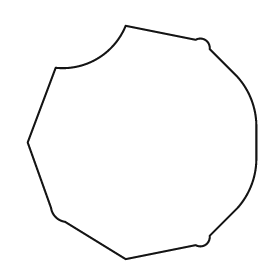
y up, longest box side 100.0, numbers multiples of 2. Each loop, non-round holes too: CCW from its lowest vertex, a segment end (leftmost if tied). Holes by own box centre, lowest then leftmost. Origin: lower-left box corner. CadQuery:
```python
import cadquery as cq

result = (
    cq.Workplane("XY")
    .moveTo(42.0, 0.0)
    .lineTo(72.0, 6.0)
    .threePointArc((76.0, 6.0), (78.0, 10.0))
    .lineTo(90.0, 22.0)
    .threePointArc((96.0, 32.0), (98.0, 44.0))
    .lineTo(98.0, 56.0)
    .threePointArc((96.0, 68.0), (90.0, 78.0))
    .lineTo(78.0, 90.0)
    .threePointArc((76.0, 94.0), (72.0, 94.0))
    .lineTo(42.0, 100.0)
    .threePointArc((30.0, 86.0), (12.0, 82.0))
    .lineTo(0.0, 50.0)
    .lineTo(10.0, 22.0)
    .threePointArc((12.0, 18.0), (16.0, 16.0))
    .close()
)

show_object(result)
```